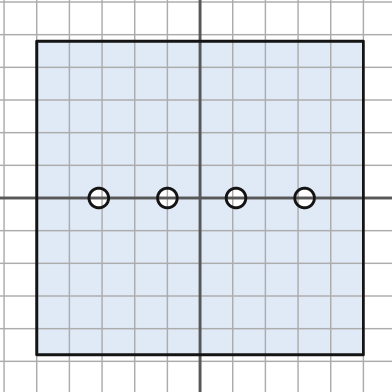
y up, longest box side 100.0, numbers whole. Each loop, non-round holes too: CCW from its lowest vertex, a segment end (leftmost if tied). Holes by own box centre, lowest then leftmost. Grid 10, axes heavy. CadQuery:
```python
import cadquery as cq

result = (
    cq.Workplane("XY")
    .moveTo(-50.0, -48.0)
    .lineTo(50.0, -48.0)
    .lineTo(50.0, 48.0)
    .lineTo(-50.0, 48.0)
    .close()
    .moveTo(-31.0, 0.0)
    .circle(3.0)
    .moveTo(-10.0, 0.0)
    .circle(3.0)
    .moveTo(11.0, 0.0)
    .circle(3.0)
    .moveTo(32.0, 0.0)
    .circle(3.0)
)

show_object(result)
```